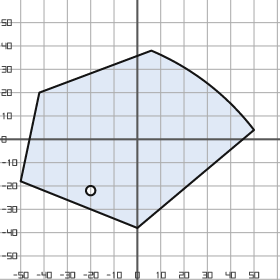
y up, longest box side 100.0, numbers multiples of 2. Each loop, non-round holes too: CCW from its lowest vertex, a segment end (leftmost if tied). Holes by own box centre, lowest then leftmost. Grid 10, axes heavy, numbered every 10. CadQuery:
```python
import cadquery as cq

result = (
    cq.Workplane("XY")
    .moveTo(0.0, -38.0)
    .lineTo(50.0, 4.0)
    .threePointArc((30.0, 24.0), (6.0, 38.0))
    .lineTo(-42.0, 20.0)
    .lineTo(-50.0, -18.0)
    .close()
    .moveTo(-20.0, -22.0)
    .circle(2.0)
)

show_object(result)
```